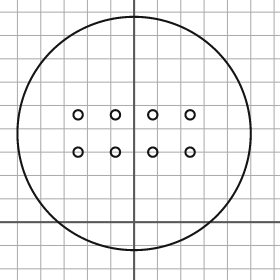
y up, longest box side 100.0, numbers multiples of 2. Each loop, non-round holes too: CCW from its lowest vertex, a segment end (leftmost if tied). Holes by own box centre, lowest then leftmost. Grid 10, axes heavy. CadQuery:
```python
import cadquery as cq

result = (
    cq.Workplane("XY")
    .moveTo(0.0, 38.0)
    .circle(50.0)
    .moveTo(-24.0, 30.0)
    .circle(2.0)
    .moveTo(-8.0, 30.0)
    .circle(2.0)
    .moveTo(8.0, 30.0)
    .circle(2.0)
    .moveTo(24.0, 30.0)
    .circle(2.0)
    .moveTo(-24.0, 46.0)
    .circle(2.0)
    .moveTo(-8.0, 46.0)
    .circle(2.0)
    .moveTo(8.0, 46.0)
    .circle(2.0)
    .moveTo(24.0, 46.0)
    .circle(2.0)
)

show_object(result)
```